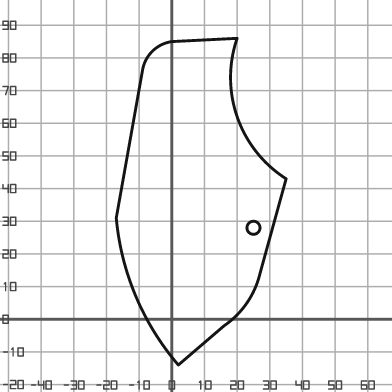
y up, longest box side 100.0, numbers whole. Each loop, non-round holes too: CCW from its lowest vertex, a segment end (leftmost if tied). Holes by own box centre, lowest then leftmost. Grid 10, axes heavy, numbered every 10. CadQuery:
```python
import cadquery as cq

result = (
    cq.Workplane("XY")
    .moveTo(2.0, -14.0)
    .lineTo(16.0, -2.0)
    .threePointArc((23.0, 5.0), (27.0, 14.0))
    .lineTo(35.0, 43.0)
    .threePointArc((20.0, 62.0), (20.0, 86.0))
    .lineTo(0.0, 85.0)
    .threePointArc((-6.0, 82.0), (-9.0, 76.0))
    .lineTo(-17.0, 31.0)
    .threePointArc((-11.0, 7.0), (2.0, -14.0))
    .close()
    .moveTo(25.0, 28.0)
    .circle(2.0)
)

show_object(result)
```